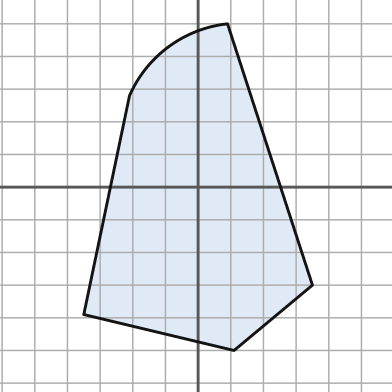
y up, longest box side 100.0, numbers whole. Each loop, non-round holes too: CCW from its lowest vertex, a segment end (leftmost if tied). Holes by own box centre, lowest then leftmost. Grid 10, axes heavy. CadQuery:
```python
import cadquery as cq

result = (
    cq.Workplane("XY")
    .moveTo(11.0, -50.0)
    .lineTo(35.0, -30.0)
    .lineTo(9.0, 50.0)
    .threePointArc((-9.0, 43.0), (-21.0, 28.0))
    .lineTo(-35.0, -39.0)
    .close()
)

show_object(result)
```